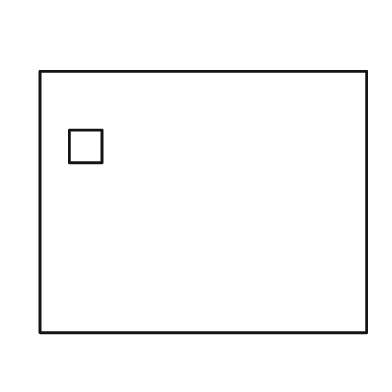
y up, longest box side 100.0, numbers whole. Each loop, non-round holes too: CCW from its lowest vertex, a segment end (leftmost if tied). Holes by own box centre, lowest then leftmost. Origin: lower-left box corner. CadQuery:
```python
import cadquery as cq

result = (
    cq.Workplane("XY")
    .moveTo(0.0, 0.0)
    .lineTo(100.0, 0.0)
    .lineTo(100.0, 80.0)
    .lineTo(0.0, 80.0)
    .close()
    .moveTo(9.0, 52.0)
    .lineTo(19.0, 52.0)
    .lineTo(19.0, 62.0)
    .lineTo(9.0, 62.0)
    .close()
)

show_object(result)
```